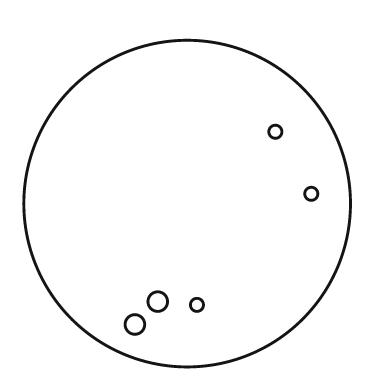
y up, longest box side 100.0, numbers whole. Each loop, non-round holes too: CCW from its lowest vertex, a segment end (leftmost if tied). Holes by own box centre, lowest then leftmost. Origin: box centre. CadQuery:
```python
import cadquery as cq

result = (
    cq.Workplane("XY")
    .moveTo(0.0, 0.0)
    .circle(50.0)
    .moveTo(-16.0, -37.0)
    .circle(3.0)
    .moveTo(3.0, -31.0)
    .circle(2.0)
    .moveTo(-9.0, -30.0)
    .circle(3.0)
    .moveTo(38.0, 3.0)
    .circle(2.0)
    .moveTo(27.0, 22.0)
    .circle(2.0)
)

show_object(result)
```